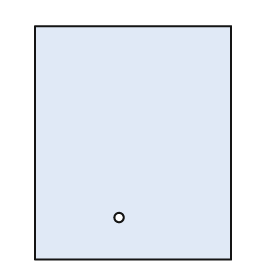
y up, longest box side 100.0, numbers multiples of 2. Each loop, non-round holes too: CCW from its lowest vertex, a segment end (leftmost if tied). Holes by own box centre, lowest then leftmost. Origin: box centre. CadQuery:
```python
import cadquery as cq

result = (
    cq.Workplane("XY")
    .moveTo(-42.0, -50.0)
    .lineTo(42.0, -50.0)
    .lineTo(42.0, 50.0)
    .lineTo(-42.0, 50.0)
    .close()
    .moveTo(-6.0, -32.0)
    .circle(2.0)
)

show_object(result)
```